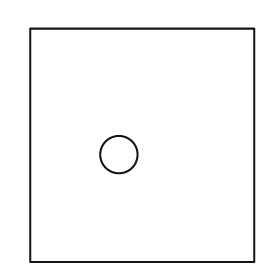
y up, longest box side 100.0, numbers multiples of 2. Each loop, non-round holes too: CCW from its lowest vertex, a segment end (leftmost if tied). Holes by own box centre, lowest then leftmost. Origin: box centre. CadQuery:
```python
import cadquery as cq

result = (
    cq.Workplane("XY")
    .moveTo(-48.0, -50.0)
    .lineTo(48.0, -50.0)
    .lineTo(48.0, 50.0)
    .lineTo(-48.0, 50.0)
    .close()
    .moveTo(-10.0, -4.0)
    .circle(8.0)
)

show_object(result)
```